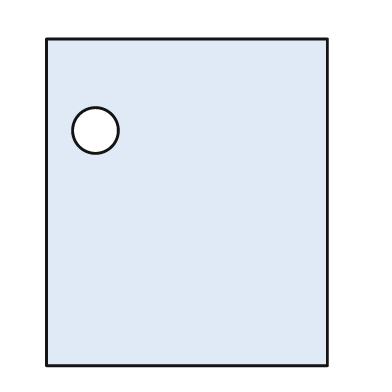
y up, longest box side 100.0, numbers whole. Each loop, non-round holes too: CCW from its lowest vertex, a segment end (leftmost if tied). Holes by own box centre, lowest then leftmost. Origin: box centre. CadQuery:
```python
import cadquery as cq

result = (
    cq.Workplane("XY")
    .moveTo(-43.0, -50.0)
    .lineTo(43.0, -50.0)
    .lineTo(43.0, 50.0)
    .lineTo(-43.0, 50.0)
    .close()
    .moveTo(-28.0, 22.0)
    .circle(7.0)
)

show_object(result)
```